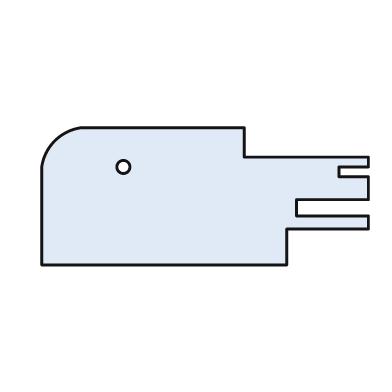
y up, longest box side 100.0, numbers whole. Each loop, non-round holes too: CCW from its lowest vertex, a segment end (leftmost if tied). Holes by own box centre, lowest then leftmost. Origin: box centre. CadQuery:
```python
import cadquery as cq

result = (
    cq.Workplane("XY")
    .moveTo(-50.0, -21.0)
    .lineTo(25.0, -21.0)
    .lineTo(25.0, -10.0)
    .lineTo(50.0, -10.0)
    .lineTo(50.0, -6.0)
    .lineTo(28.0, -6.0)
    .lineTo(28.0, -1.0)
    .lineTo(50.0, -1.0)
    .lineTo(50.0, 6.0)
    .lineTo(41.0, 6.0)
    .lineTo(41.0, 9.0)
    .lineTo(50.0, 9.0)
    .lineTo(50.0, 12.0)
    .lineTo(12.0, 12.0)
    .lineTo(12.0, 21.0)
    .lineTo(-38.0, 21.0)
    .threePointArc((-46.0, 17.0), (-50.0, 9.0))
    .close()
    .moveTo(-25.0, 9.0)
    .circle(2.0)
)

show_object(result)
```